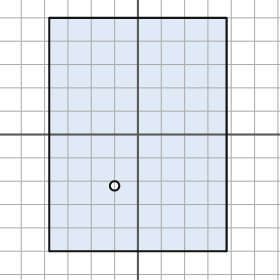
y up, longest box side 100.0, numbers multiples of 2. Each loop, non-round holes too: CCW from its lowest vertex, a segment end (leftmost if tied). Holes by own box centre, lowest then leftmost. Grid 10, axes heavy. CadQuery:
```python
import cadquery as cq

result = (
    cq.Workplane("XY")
    .moveTo(-38.0, -50.0)
    .lineTo(38.0, -50.0)
    .lineTo(38.0, 50.0)
    .lineTo(-38.0, 50.0)
    .close()
    .moveTo(-10.0, -22.0)
    .circle(2.0)
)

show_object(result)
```